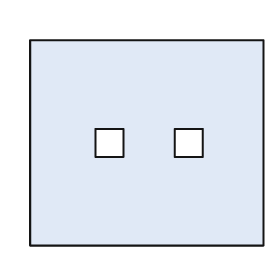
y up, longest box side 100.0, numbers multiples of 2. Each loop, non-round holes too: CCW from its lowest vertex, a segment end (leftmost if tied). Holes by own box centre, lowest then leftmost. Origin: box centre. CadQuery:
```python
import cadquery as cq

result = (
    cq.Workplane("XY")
    .moveTo(-50.0, -44.0)
    .lineTo(50.0, -44.0)
    .lineTo(50.0, 44.0)
    .lineTo(-50.0, 44.0)
    .close()
    .moveTo(-22.0, -6.0)
    .lineTo(-10.0, -6.0)
    .lineTo(-10.0, 6.0)
    .lineTo(-22.0, 6.0)
    .close()
    .moveTo(12.0, -6.0)
    .lineTo(24.0, -6.0)
    .lineTo(24.0, 6.0)
    .lineTo(12.0, 6.0)
    .close()
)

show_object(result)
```